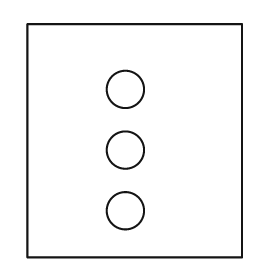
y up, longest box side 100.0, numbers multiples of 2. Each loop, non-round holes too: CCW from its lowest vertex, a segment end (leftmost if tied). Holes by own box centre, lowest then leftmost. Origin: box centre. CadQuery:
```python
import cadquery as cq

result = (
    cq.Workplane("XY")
    .moveTo(-46.0, -50.0)
    .lineTo(46.0, -50.0)
    .lineTo(46.0, 50.0)
    .lineTo(-46.0, 50.0)
    .close()
    .moveTo(-4.0, -30.0)
    .circle(8.0)
    .moveTo(-4.0, -4.0)
    .circle(8.0)
    .moveTo(-4.0, 22.0)
    .circle(8.0)
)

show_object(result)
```